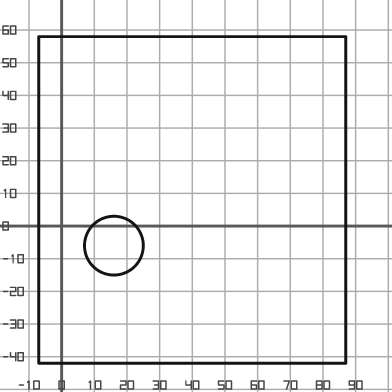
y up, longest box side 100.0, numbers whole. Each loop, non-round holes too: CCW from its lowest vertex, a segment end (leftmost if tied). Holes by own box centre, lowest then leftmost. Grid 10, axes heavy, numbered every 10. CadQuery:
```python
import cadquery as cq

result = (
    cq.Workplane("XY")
    .moveTo(-7.0, -42.0)
    .lineTo(87.0, -42.0)
    .lineTo(87.0, 58.0)
    .lineTo(-7.0, 58.0)
    .close()
    .moveTo(16.0, -6.0)
    .circle(9.0)
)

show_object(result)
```